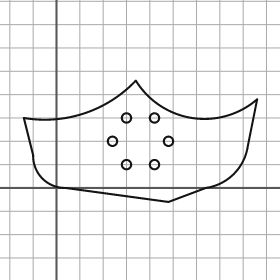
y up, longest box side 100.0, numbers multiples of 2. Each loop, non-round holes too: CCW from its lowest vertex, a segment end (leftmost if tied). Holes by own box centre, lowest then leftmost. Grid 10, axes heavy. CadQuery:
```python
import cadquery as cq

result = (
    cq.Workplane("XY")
    .moveTo(48.0, -6.0)
    .lineTo(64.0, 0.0)
    .threePointArc((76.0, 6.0), (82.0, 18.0))
    .lineTo(86.0, 38.0)
    .threePointArc((58.0, 30.0), (34.0, 46.0))
    .threePointArc((12.0, 32.0), (-14.0, 30.0))
    .lineTo(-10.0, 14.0)
    .threePointArc((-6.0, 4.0), (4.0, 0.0))
    .close()
    .moveTo(30.0, 10.0)
    .circle(2.0)
    .moveTo(42.0, 10.0)
    .circle(2.0)
    .moveTo(24.0, 20.0)
    .circle(2.0)
    .moveTo(48.0, 20.0)
    .circle(2.0)
    .moveTo(30.0, 30.0)
    .circle(2.0)
    .moveTo(42.0, 30.0)
    .circle(2.0)
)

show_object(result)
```